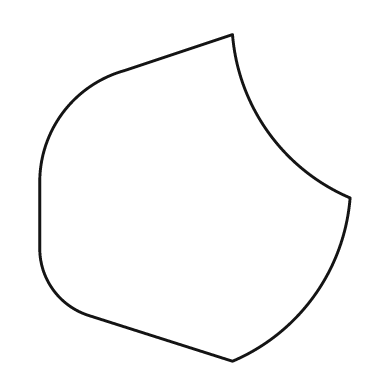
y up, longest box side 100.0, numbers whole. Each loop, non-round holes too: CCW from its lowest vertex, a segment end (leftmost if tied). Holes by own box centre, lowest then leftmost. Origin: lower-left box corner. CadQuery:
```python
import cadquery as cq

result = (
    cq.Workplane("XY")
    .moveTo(59.0, 0.0)
    .threePointArc((84.0, 20.0), (95.0, 50.0))
    .threePointArc((70.0, 70.0), (59.0, 100.0))
    .lineTo(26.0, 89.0)
    .threePointArc((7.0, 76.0), (0.0, 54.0))
    .lineTo(0.0, 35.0)
    .threePointArc((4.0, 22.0), (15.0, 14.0))
    .close()
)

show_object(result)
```